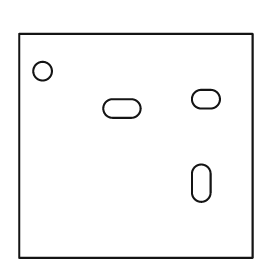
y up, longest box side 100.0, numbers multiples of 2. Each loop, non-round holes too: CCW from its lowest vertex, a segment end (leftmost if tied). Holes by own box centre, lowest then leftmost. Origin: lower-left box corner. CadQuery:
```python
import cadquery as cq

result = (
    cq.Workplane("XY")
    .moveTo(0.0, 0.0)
    .lineTo(100.0, 0.0)
    .lineTo(100.0, 96.0)
    .lineTo(0.0, 96.0)
    .close()
    .moveTo(74.0, 28.0)
    .threePointArc((78.0, 24.0), (82.0, 28.0))
    .lineTo(82.0, 36.0)
    .threePointArc((78.0, 40.0), (74.0, 36.0))
    .close()
    .moveTo(40.0, 60.0)
    .lineTo(48.0, 60.0)
    .threePointArc((52.0, 64.0), (48.0, 68.0))
    .lineTo(40.0, 68.0)
    .threePointArc((36.0, 64.0), (40.0, 60.0))
    .close()
    .moveTo(78.0, 64.0)
    .lineTo(82.0, 64.0)
    .threePointArc((86.0, 68.0), (82.0, 72.0))
    .lineTo(78.0, 72.0)
    .threePointArc((74.0, 68.0), (78.0, 64.0))
    .close()
    .moveTo(10.0, 80.0)
    .circle(4.0)
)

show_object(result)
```